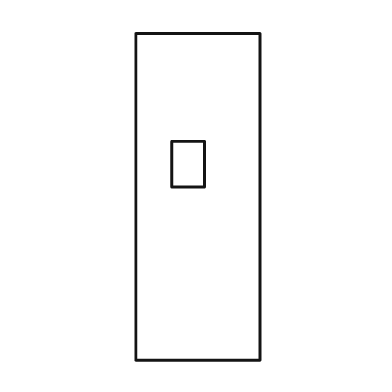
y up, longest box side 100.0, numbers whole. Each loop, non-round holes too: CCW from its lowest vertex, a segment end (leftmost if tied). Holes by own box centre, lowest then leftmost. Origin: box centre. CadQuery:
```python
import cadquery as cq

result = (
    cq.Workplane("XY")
    .moveTo(-19.0, -50.0)
    .lineTo(19.0, -50.0)
    .lineTo(19.0, 50.0)
    .lineTo(-19.0, 50.0)
    .close()
    .moveTo(-8.0, 3.0)
    .lineTo(2.0, 3.0)
    .lineTo(2.0, 17.0)
    .lineTo(-8.0, 17.0)
    .close()
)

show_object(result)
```